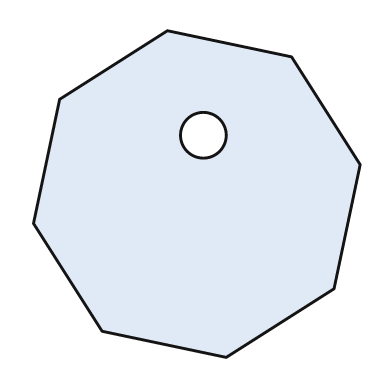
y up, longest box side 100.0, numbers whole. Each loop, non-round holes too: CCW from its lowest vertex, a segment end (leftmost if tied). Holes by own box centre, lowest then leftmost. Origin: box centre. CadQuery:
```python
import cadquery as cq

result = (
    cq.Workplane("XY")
    .moveTo(9.0, -50.0)
    .lineTo(42.0, -29.0)
    .lineTo(50.0, 9.0)
    .lineTo(29.0, 42.0)
    .lineTo(-9.0, 50.0)
    .lineTo(-42.0, 29.0)
    .lineTo(-50.0, -9.0)
    .lineTo(-29.0, -42.0)
    .close()
    .moveTo(2.0, 18.0)
    .circle(7.0)
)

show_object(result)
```